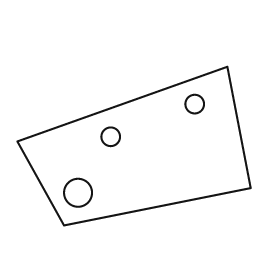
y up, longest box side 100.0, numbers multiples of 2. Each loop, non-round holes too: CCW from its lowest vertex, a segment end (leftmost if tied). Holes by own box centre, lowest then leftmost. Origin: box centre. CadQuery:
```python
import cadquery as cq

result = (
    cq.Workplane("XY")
    .moveTo(-30.0, -34.0)
    .lineTo(50.0, -18.0)
    .lineTo(40.0, 34.0)
    .lineTo(-50.0, 2.0)
    .close()
    .moveTo(-24.0, -20.0)
    .circle(6.0)
    .moveTo(-10.0, 4.0)
    .circle(4.0)
    .moveTo(26.0, 18.0)
    .circle(4.0)
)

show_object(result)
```